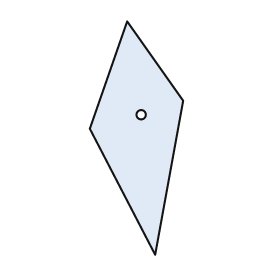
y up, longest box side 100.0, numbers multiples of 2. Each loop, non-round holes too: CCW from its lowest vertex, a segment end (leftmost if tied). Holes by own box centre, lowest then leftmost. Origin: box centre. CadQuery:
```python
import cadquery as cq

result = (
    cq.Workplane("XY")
    .moveTo(8.0, -50.0)
    .lineTo(20.0, 16.0)
    .lineTo(-4.0, 50.0)
    .lineTo(-20.0, 4.0)
    .close()
    .moveTo(2.0, 10.0)
    .circle(2.0)
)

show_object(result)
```